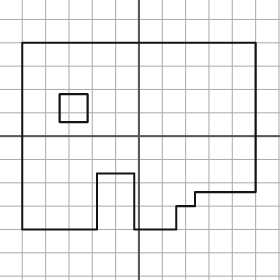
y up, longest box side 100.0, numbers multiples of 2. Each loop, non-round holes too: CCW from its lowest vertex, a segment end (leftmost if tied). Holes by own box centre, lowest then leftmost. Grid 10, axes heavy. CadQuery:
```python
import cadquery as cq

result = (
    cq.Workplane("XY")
    .moveTo(-50.0, -40.0)
    .lineTo(-18.0, -40.0)
    .lineTo(-18.0, -16.0)
    .lineTo(-2.0, -16.0)
    .lineTo(-2.0, -40.0)
    .lineTo(16.0, -40.0)
    .lineTo(16.0, -30.0)
    .lineTo(24.0, -30.0)
    .lineTo(24.0, -24.0)
    .lineTo(50.0, -24.0)
    .lineTo(50.0, 40.0)
    .lineTo(-50.0, 40.0)
    .close()
    .moveTo(-34.0, 6.0)
    .lineTo(-22.0, 6.0)
    .lineTo(-22.0, 18.0)
    .lineTo(-34.0, 18.0)
    .close()
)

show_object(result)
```